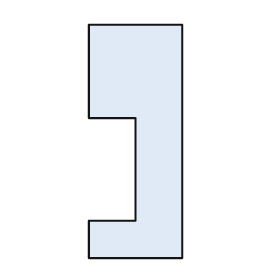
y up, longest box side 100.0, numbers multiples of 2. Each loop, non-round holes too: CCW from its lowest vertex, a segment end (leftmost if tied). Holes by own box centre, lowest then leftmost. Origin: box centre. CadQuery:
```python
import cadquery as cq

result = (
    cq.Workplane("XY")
    .moveTo(-20.0, -50.0)
    .lineTo(20.0, -50.0)
    .lineTo(20.0, 50.0)
    .lineTo(-20.0, 50.0)
    .lineTo(-20.0, 10.0)
    .lineTo(0.0, 10.0)
    .lineTo(0.0, -34.0)
    .lineTo(-20.0, -34.0)
    .close()
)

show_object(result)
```